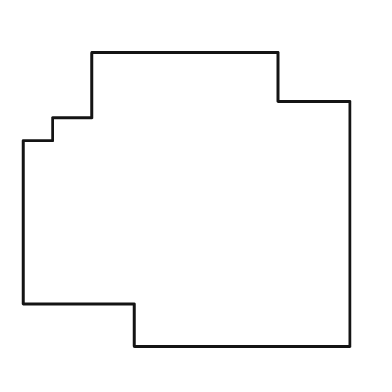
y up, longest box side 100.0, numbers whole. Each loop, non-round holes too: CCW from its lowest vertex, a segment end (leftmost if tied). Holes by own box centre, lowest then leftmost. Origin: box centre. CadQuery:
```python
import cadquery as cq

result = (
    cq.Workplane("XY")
    .moveTo(-16.0, -45.0)
    .lineTo(50.0, -45.0)
    .lineTo(50.0, 30.0)
    .lineTo(28.0, 30.0)
    .lineTo(28.0, 45.0)
    .lineTo(-29.0, 45.0)
    .lineTo(-29.0, 25.0)
    .lineTo(-41.0, 25.0)
    .lineTo(-41.0, 18.0)
    .lineTo(-50.0, 18.0)
    .lineTo(-50.0, -32.0)
    .lineTo(-16.0, -32.0)
    .close()
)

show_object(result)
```